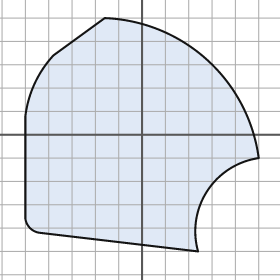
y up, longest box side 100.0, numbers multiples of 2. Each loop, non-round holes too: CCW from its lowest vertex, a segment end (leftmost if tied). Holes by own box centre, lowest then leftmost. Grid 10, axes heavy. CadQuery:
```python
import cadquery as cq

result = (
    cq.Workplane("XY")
    .moveTo(24.0, -50.0)
    .threePointArc((28.0, -24.0), (50.0, -10.0))
    .threePointArc((28.0, 32.0), (-16.0, 50.0))
    .lineTo(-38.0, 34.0)
    .threePointArc((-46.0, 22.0), (-50.0, 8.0))
    .lineTo(-50.0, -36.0)
    .threePointArc((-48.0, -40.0), (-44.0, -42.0))
    .close()
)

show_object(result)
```